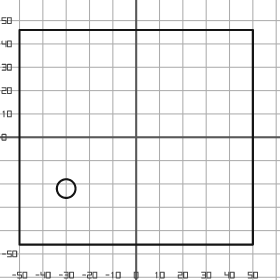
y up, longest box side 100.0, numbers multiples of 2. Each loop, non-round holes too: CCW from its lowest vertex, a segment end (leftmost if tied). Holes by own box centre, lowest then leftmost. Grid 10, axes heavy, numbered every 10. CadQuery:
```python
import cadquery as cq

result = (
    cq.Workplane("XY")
    .moveTo(-50.0, -46.0)
    .lineTo(50.0, -46.0)
    .lineTo(50.0, 46.0)
    .lineTo(-50.0, 46.0)
    .close()
    .moveTo(-30.0, -22.0)
    .circle(4.0)
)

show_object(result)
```